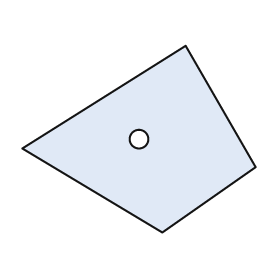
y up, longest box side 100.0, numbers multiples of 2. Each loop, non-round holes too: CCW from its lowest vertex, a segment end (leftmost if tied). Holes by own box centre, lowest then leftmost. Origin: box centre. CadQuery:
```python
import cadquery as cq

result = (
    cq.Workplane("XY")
    .moveTo(10.0, -40.0)
    .lineTo(50.0, -12.0)
    .lineTo(20.0, 40.0)
    .lineTo(-50.0, -4.0)
    .close()
    .moveTo(0.0, 0.0)
    .circle(4.0)
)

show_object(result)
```